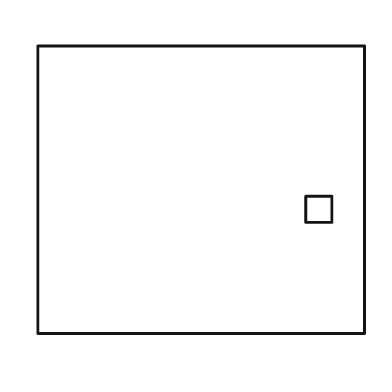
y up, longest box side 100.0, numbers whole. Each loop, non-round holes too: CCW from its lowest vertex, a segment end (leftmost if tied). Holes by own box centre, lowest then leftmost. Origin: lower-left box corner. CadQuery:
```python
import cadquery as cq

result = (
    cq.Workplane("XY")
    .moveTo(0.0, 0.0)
    .lineTo(100.0, 0.0)
    .lineTo(100.0, 88.0)
    .lineTo(0.0, 88.0)
    .close()
    .moveTo(82.0, 34.0)
    .lineTo(90.0, 34.0)
    .lineTo(90.0, 42.0)
    .lineTo(82.0, 42.0)
    .close()
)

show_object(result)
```